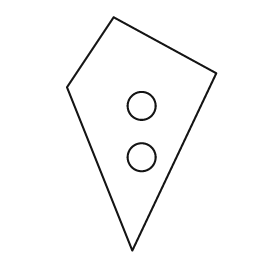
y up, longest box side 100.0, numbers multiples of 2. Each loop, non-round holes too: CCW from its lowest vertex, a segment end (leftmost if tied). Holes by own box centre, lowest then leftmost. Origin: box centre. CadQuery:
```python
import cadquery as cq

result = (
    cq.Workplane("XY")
    .moveTo(-4.0, -50.0)
    .lineTo(32.0, 26.0)
    .lineTo(-12.0, 50.0)
    .lineTo(-32.0, 20.0)
    .close()
    .moveTo(0.0, -10.0)
    .circle(6.0)
    .moveTo(0.0, 12.0)
    .circle(6.0)
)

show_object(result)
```